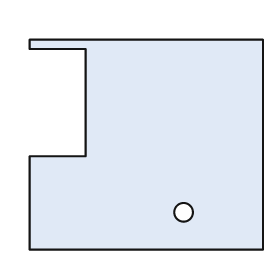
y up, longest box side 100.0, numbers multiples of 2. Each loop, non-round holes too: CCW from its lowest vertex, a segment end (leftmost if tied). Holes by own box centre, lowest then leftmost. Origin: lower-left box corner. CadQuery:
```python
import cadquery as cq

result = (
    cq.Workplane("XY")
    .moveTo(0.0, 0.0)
    .lineTo(100.0, 0.0)
    .lineTo(100.0, 90.0)
    .lineTo(0.0, 90.0)
    .lineTo(0.0, 86.0)
    .lineTo(24.0, 86.0)
    .lineTo(24.0, 40.0)
    .lineTo(0.0, 40.0)
    .close()
    .moveTo(66.0, 16.0)
    .circle(4.0)
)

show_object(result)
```